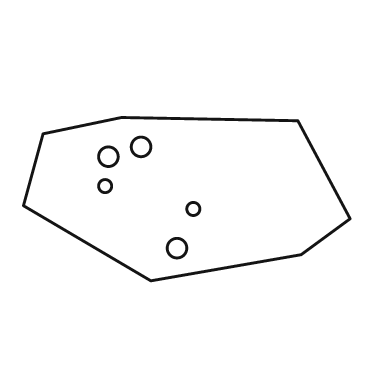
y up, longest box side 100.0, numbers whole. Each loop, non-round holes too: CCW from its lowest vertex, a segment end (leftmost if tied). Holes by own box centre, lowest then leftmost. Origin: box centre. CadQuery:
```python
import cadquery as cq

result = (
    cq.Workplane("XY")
    .moveTo(-11.0, -25.0)
    .lineTo(35.0, -17.0)
    .lineTo(50.0, -6.0)
    .lineTo(34.0, 24.0)
    .lineTo(-20.0, 25.0)
    .lineTo(-44.0, 20.0)
    .lineTo(-50.0, -2.0)
    .close()
    .moveTo(-3.0, -15.0)
    .circle(3.0)
    .moveTo(2.0, -3.0)
    .circle(2.0)
    .moveTo(-25.0, 4.0)
    .circle(2.0)
    .moveTo(-24.0, 13.0)
    .circle(3.0)
    .moveTo(-14.0, 16.0)
    .circle(3.0)
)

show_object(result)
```